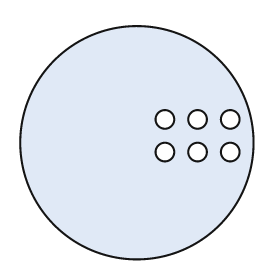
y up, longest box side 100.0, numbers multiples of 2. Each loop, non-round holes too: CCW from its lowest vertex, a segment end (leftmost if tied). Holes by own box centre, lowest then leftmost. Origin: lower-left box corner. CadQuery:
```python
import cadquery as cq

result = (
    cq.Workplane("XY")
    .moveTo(50.0, 50.0)
    .circle(50.0)
    .moveTo(62.0, 46.0)
    .circle(4.0)
    .moveTo(76.0, 46.0)
    .circle(4.0)
    .moveTo(90.0, 46.0)
    .circle(4.0)
    .moveTo(62.0, 60.0)
    .circle(4.0)
    .moveTo(76.0, 60.0)
    .circle(4.0)
    .moveTo(90.0, 60.0)
    .circle(4.0)
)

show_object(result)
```